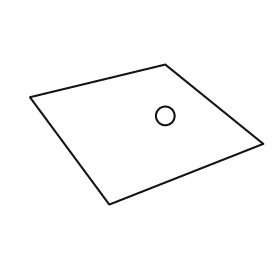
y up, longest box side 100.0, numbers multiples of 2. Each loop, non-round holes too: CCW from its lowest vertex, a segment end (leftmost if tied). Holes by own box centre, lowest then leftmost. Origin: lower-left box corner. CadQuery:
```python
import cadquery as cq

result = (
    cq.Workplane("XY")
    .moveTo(34.0, 0.0)
    .lineTo(100.0, 26.0)
    .lineTo(58.0, 60.0)
    .lineTo(0.0, 46.0)
    .close()
    .moveTo(58.0, 38.0)
    .circle(4.0)
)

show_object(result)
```